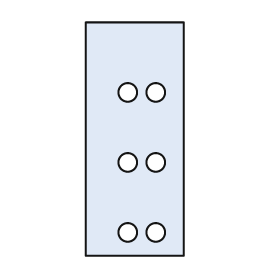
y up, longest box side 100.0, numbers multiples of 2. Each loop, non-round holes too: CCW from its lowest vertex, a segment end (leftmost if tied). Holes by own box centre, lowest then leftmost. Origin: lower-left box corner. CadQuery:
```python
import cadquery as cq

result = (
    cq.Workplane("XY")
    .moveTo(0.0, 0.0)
    .lineTo(42.0, 0.0)
    .lineTo(42.0, 100.0)
    .lineTo(0.0, 100.0)
    .close()
    .moveTo(18.0, 10.0)
    .circle(4.0)
    .moveTo(30.0, 10.0)
    .circle(4.0)
    .moveTo(18.0, 40.0)
    .circle(4.0)
    .moveTo(30.0, 40.0)
    .circle(4.0)
    .moveTo(18.0, 70.0)
    .circle(4.0)
    .moveTo(30.0, 70.0)
    .circle(4.0)
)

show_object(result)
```